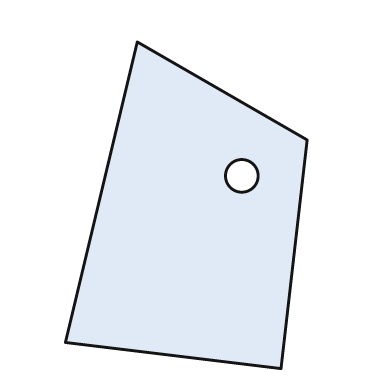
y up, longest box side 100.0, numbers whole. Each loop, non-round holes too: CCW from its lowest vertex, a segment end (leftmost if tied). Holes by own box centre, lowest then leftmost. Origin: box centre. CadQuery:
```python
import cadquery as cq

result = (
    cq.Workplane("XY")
    .moveTo(29.0, -50.0)
    .lineTo(37.0, 20.0)
    .lineTo(-15.0, 50.0)
    .lineTo(-37.0, -42.0)
    .close()
    .moveTo(17.0, 9.0)
    .circle(5.0)
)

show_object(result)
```